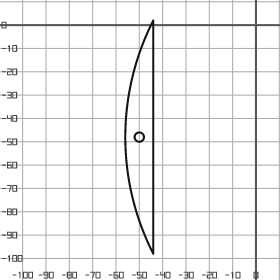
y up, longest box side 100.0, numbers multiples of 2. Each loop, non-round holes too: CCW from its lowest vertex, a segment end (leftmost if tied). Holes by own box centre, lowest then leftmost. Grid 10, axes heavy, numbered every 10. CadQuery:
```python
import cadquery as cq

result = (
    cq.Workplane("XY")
    .moveTo(-44.0, -98.0)
    .lineTo(-44.0, 2.0)
    .threePointArc((-56.0, -48.0), (-44.0, -98.0))
    .close()
    .moveTo(-50.0, -48.0)
    .circle(2.0)
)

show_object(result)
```